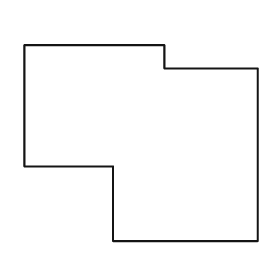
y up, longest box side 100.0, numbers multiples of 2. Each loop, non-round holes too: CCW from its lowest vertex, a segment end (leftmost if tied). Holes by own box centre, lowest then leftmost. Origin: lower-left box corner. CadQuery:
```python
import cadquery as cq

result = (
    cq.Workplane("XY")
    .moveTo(38.0, 0.0)
    .lineTo(100.0, 0.0)
    .lineTo(100.0, 74.0)
    .lineTo(60.0, 74.0)
    .lineTo(60.0, 84.0)
    .lineTo(0.0, 84.0)
    .lineTo(0.0, 32.0)
    .lineTo(38.0, 32.0)
    .close()
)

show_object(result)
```